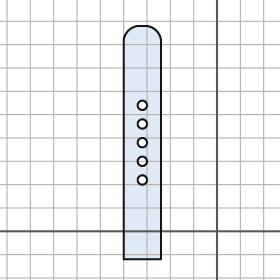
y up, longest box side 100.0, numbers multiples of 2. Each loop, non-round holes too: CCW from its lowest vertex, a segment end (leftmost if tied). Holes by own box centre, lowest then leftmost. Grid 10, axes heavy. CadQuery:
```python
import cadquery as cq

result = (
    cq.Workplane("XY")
    .moveTo(-40.0, -12.0)
    .lineTo(-24.0, -12.0)
    .lineTo(-24.0, 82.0)
    .threePointArc((-26.0, 86.0), (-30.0, 88.0))
    .lineTo(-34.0, 88.0)
    .threePointArc((-38.0, 86.0), (-40.0, 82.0))
    .close()
    .moveTo(-32.0, 22.0)
    .circle(2.0)
    .moveTo(-32.0, 30.0)
    .circle(2.0)
    .moveTo(-32.0, 38.0)
    .circle(2.0)
    .moveTo(-32.0, 46.0)
    .circle(2.0)
    .moveTo(-32.0, 54.0)
    .circle(2.0)
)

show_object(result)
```